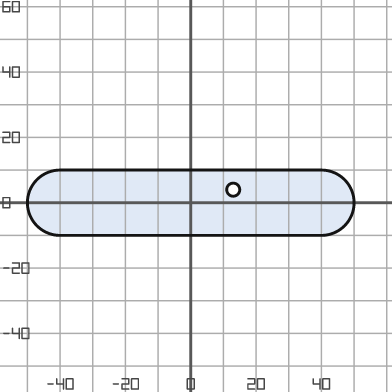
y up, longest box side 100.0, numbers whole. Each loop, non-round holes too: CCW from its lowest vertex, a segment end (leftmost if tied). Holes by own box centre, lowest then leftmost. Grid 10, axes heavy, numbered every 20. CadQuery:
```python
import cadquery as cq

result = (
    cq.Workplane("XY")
    .moveTo(-40.0, -10.0)
    .lineTo(40.0, -10.0)
    .threePointArc((50.0, 0.0), (40.0, 10.0))
    .lineTo(-40.0, 10.0)
    .threePointArc((-50.0, 0.0), (-40.0, -10.0))
    .close()
    .moveTo(13.0, 4.0)
    .circle(2.0)
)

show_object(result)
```